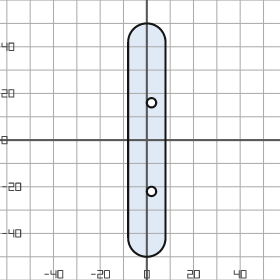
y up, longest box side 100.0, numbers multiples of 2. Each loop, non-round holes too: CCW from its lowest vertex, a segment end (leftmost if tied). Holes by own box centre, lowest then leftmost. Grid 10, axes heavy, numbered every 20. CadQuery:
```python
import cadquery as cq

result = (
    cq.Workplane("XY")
    .moveTo(-8.0, -42.0)
    .threePointArc((0.0, -50.0), (8.0, -42.0))
    .lineTo(8.0, 42.0)
    .threePointArc((0.0, 50.0), (-8.0, 42.0))
    .close()
    .moveTo(2.0, -22.0)
    .circle(2.0)
    .moveTo(2.0, 16.0)
    .circle(2.0)
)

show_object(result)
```